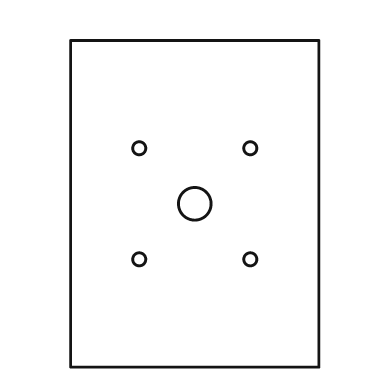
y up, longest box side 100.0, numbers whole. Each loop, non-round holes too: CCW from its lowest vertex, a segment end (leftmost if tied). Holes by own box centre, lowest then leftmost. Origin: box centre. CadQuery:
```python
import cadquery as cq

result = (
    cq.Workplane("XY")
    .moveTo(-38.0, -50.0)
    .lineTo(38.0, -50.0)
    .lineTo(38.0, 50.0)
    .lineTo(-38.0, 50.0)
    .close()
    .moveTo(-17.0, -17.0)
    .circle(2.0)
    .moveTo(17.0, -17.0)
    .circle(2.0)
    .moveTo(0.0, 0.0)
    .circle(5.0)
    .moveTo(-17.0, 17.0)
    .circle(2.0)
    .moveTo(17.0, 17.0)
    .circle(2.0)
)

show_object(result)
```